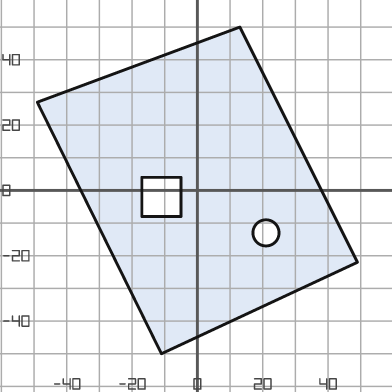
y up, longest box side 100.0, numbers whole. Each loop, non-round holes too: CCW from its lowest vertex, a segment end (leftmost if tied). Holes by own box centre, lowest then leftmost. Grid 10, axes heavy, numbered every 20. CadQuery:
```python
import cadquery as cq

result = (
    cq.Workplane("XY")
    .moveTo(-11.0, -50.0)
    .lineTo(49.0, -22.0)
    .lineTo(13.0, 50.0)
    .lineTo(-49.0, 27.0)
    .close()
    .moveTo(21.0, -13.0)
    .circle(4.0)
    .moveTo(-17.0, -8.0)
    .lineTo(-5.0, -8.0)
    .lineTo(-5.0, 4.0)
    .lineTo(-17.0, 4.0)
    .close()
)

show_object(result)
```